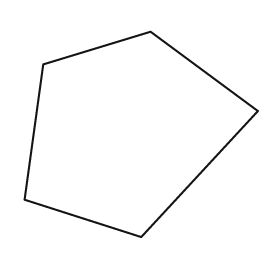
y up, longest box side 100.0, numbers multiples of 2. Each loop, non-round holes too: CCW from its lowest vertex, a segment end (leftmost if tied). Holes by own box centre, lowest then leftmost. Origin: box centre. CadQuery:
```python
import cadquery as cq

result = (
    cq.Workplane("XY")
    .moveTo(0.0, -44.0)
    .lineTo(50.0, 10.0)
    .lineTo(4.0, 44.0)
    .lineTo(-42.0, 30.0)
    .lineTo(-50.0, -28.0)
    .close()
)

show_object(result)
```